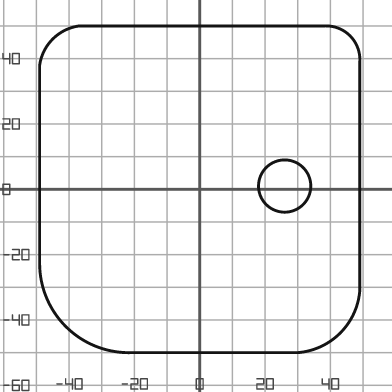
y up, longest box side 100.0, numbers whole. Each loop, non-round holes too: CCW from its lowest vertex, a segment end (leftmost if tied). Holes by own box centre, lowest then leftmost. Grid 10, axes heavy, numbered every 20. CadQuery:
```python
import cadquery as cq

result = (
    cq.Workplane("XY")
    .moveTo(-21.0, -50.0)
    .lineTo(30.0, -50.0)
    .threePointArc((43.0, -44.0), (49.0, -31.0))
    .lineTo(49.0, 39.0)
    .threePointArc((46.0, 47.0), (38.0, 50.0))
    .lineTo(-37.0, 50.0)
    .threePointArc((-45.0, 46.0), (-49.0, 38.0))
    .lineTo(-49.0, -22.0)
    .threePointArc((-41.0, -42.0), (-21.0, -50.0))
    .close()
    .moveTo(26.0, 1.0)
    .circle(8.0)
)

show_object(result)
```